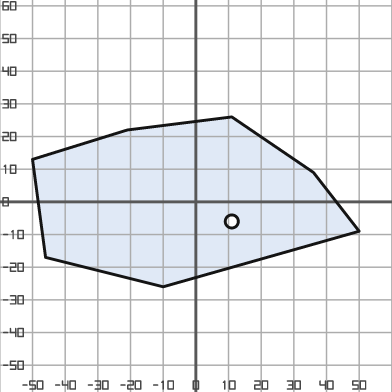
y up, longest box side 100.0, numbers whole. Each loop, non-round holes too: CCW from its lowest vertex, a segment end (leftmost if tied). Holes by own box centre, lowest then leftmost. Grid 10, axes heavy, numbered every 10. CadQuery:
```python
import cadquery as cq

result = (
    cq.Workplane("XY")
    .moveTo(-10.0, -26.0)
    .lineTo(50.0, -9.0)
    .lineTo(36.0, 9.0)
    .lineTo(11.0, 26.0)
    .lineTo(-21.0, 22.0)
    .lineTo(-50.0, 13.0)
    .lineTo(-46.0, -17.0)
    .close()
    .moveTo(11.0, -6.0)
    .circle(2.0)
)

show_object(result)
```